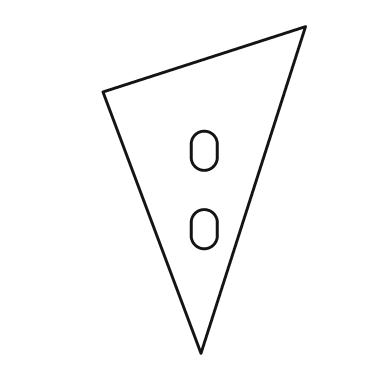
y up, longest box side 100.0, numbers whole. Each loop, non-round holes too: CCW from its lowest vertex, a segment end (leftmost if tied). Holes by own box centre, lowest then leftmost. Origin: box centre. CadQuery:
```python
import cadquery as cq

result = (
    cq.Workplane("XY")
    .moveTo(-1.0, -50.0)
    .lineTo(31.0, 50.0)
    .lineTo(-31.0, 30.0)
    .close()
    .moveTo(-4.0, -14.0)
    .threePointArc((0.0, -18.0), (4.0, -14.0))
    .lineTo(4.0, -10.0)
    .threePointArc((0.0, -6.0), (-4.0, -10.0))
    .close()
    .moveTo(-4.0, 10.0)
    .threePointArc((0.0, 6.0), (4.0, 10.0))
    .lineTo(4.0, 14.0)
    .threePointArc((0.0, 18.0), (-4.0, 14.0))
    .close()
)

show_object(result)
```